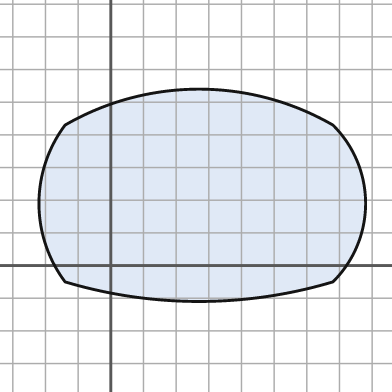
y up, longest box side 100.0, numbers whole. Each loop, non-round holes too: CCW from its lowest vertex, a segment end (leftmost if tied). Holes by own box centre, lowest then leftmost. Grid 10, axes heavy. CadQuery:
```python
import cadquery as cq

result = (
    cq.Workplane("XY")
    .moveTo(-14.0, -5.0)
    .threePointArc((27.0, -11.0), (68.0, -5.0))
    .threePointArc((78.0, 19.0), (68.0, 43.0))
    .threePointArc((27.0, 54.0), (-14.0, 43.0))
    .threePointArc((-22.0, 19.0), (-14.0, -5.0))
    .close()
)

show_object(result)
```